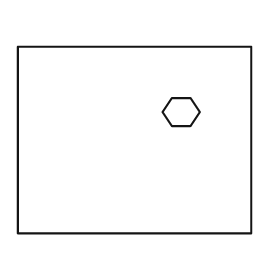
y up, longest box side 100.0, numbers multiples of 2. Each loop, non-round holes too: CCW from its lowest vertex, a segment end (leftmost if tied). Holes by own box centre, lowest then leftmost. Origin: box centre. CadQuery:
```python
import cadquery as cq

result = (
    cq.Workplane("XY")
    .moveTo(-50.0, -40.0)
    .lineTo(50.0, -40.0)
    .lineTo(50.0, 40.0)
    .lineTo(-50.0, 40.0)
    .close()
    .moveTo(16.0, 6.0)
    .lineTo(24.0, 6.0)
    .lineTo(28.0, 12.0)
    .lineTo(24.0, 18.0)
    .lineTo(16.0, 18.0)
    .lineTo(12.0, 12.0)
    .close()
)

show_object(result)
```